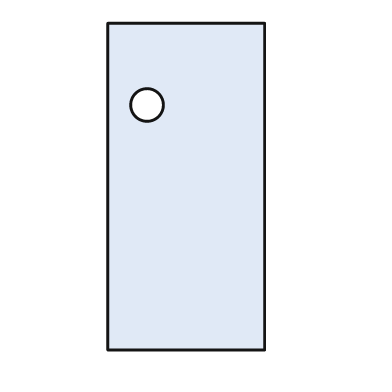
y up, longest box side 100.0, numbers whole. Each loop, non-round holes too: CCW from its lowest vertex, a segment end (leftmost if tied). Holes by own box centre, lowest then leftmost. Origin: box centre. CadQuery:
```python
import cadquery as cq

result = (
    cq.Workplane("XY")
    .moveTo(-24.0, -50.0)
    .lineTo(24.0, -50.0)
    .lineTo(24.0, 50.0)
    .lineTo(-24.0, 50.0)
    .close()
    .moveTo(-12.0, 25.0)
    .circle(5.0)
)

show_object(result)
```